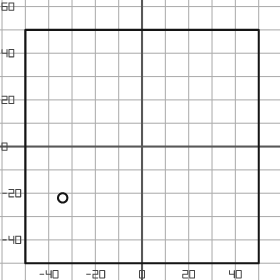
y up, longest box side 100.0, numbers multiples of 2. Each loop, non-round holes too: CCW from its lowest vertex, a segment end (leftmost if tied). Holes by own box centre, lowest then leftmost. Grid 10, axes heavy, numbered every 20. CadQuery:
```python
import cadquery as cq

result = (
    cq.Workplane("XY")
    .moveTo(-50.0, -50.0)
    .lineTo(50.0, -50.0)
    .lineTo(50.0, 50.0)
    .lineTo(-50.0, 50.0)
    .close()
    .moveTo(-34.0, -22.0)
    .circle(2.0)
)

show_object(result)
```